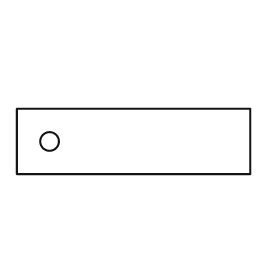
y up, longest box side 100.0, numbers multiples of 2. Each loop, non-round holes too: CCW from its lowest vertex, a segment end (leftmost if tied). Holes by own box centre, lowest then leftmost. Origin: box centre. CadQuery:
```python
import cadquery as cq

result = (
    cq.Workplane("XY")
    .moveTo(-50.0, -14.0)
    .lineTo(50.0, -14.0)
    .lineTo(50.0, 14.0)
    .lineTo(-50.0, 14.0)
    .close()
    .moveTo(-36.0, 0.0)
    .circle(4.0)
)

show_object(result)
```